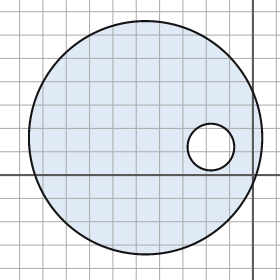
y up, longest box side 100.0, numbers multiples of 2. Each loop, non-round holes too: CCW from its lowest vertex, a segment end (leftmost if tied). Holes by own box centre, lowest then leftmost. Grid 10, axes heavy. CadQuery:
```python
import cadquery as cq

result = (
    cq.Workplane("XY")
    .moveTo(-46.0, 16.0)
    .circle(50.0)
    .moveTo(-18.0, 12.0)
    .circle(10.0)
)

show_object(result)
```